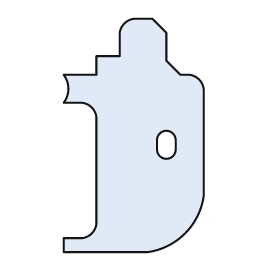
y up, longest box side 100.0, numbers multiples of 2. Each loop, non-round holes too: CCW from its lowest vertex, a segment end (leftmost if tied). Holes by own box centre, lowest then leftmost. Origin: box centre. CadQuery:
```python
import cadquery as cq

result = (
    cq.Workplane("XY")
    .moveTo(-30.0, -50.0)
    .lineTo(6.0, -50.0)
    .threePointArc((22.0, -42.0), (30.0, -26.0))
    .lineTo(30.0, 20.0)
    .threePointArc((28.0, 24.0), (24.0, 26.0))
    .lineTo(20.0, 26.0)
    .lineTo(14.0, 32.0)
    .lineTo(14.0, 44.0)
    .lineTo(8.0, 50.0)
    .lineTo(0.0, 50.0)
    .threePointArc((-4.0, 48.0), (-6.0, 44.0))
    .lineTo(-6.0, 34.0)
    .lineTo(-16.0, 34.0)
    .lineTo(-16.0, 26.0)
    .lineTo(-30.0, 26.0)
    .threePointArc((-28.0, 20.0), (-30.0, 14.0))
    .lineTo(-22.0, 14.0)
    .threePointArc((-18.0, 12.0), (-16.0, 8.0))
    .lineTo(-16.0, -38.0)
    .threePointArc((-18.0, -42.0), (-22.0, -44.0))
    .lineTo(-30.0, -44.0)
    .close()
    .moveTo(10.0, -6.0)
    .threePointArc((14.0, -10.0), (18.0, -6.0))
    .lineTo(18.0, -2.0)
    .threePointArc((14.0, 2.0), (10.0, -2.0))
    .close()
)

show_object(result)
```